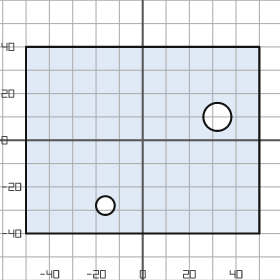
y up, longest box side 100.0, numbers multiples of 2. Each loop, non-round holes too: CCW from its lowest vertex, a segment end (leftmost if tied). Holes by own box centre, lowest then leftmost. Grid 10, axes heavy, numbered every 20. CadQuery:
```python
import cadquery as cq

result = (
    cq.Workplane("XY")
    .moveTo(-50.0, -40.0)
    .lineTo(50.0, -40.0)
    .lineTo(50.0, 40.0)
    .lineTo(-50.0, 40.0)
    .close()
    .moveTo(-16.0, -28.0)
    .circle(4.0)
    .moveTo(32.0, 10.0)
    .circle(6.0)
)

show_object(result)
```